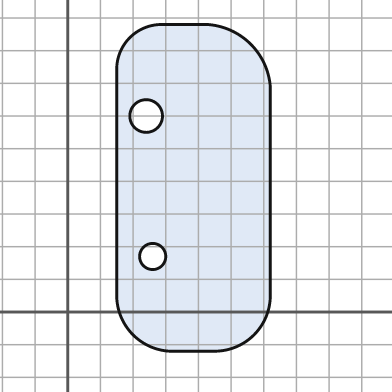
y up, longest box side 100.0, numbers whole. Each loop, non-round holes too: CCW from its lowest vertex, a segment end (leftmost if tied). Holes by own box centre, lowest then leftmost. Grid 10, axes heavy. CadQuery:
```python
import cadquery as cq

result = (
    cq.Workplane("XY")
    .moveTo(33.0, -12.0)
    .lineTo(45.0, -12.0)
    .threePointArc((57.0, -7.0), (62.0, 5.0))
    .lineTo(62.0, 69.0)
    .threePointArc((56.0, 82.0), (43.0, 88.0))
    .lineTo(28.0, 88.0)
    .threePointArc((19.0, 84.0), (15.0, 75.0))
    .lineTo(15.0, 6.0)
    .threePointArc((20.0, -7.0), (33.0, -12.0))
    .close()
    .moveTo(26.0, 17.0)
    .circle(4.0)
    .moveTo(24.0, 60.0)
    .circle(5.0)
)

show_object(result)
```